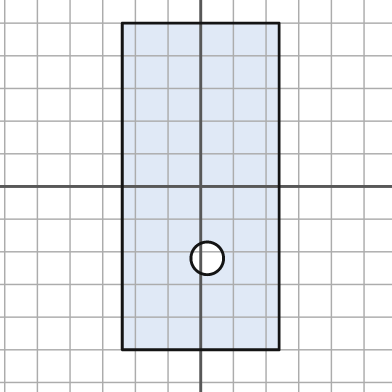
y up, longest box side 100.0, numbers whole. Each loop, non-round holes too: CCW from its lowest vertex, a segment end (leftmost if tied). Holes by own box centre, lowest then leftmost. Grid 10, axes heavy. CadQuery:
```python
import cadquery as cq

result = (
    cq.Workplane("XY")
    .moveTo(-24.0, -50.0)
    .lineTo(24.0, -50.0)
    .lineTo(24.0, 50.0)
    .lineTo(-24.0, 50.0)
    .close()
    .moveTo(2.0, -22.0)
    .circle(5.0)
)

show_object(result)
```